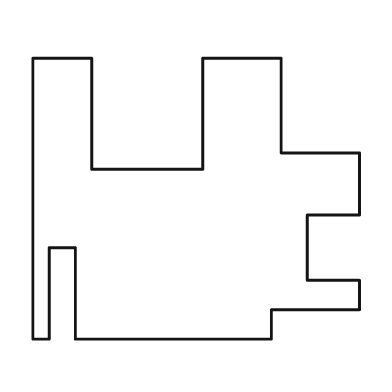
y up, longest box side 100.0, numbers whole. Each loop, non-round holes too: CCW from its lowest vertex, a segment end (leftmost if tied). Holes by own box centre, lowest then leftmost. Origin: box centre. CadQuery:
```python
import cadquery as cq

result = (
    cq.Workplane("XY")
    .moveTo(-50.0, -43.0)
    .lineTo(-45.0, -43.0)
    .lineTo(-45.0, -15.0)
    .lineTo(-37.0, -15.0)
    .lineTo(-37.0, -43.0)
    .lineTo(23.0, -43.0)
    .lineTo(23.0, -34.0)
    .lineTo(50.0, -34.0)
    .lineTo(50.0, -25.0)
    .lineTo(34.0, -25.0)
    .lineTo(34.0, -5.0)
    .lineTo(50.0, -5.0)
    .lineTo(50.0, 14.0)
    .lineTo(26.0, 14.0)
    .lineTo(26.0, 43.0)
    .lineTo(2.0, 43.0)
    .lineTo(2.0, 9.0)
    .lineTo(-32.0, 9.0)
    .lineTo(-32.0, 43.0)
    .lineTo(-50.0, 43.0)
    .close()
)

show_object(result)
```